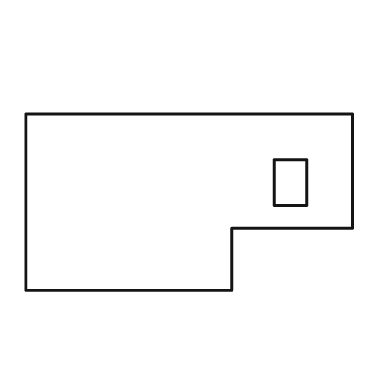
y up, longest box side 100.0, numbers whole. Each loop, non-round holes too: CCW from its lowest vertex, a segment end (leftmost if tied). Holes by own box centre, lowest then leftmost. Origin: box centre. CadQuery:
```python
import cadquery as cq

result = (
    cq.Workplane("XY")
    .moveTo(-50.0, -27.0)
    .lineTo(13.0, -27.0)
    .lineTo(13.0, -8.0)
    .lineTo(50.0, -8.0)
    .lineTo(50.0, 27.0)
    .lineTo(-50.0, 27.0)
    .close()
    .moveTo(26.0, -1.0)
    .lineTo(36.0, -1.0)
    .lineTo(36.0, 13.0)
    .lineTo(26.0, 13.0)
    .close()
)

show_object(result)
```